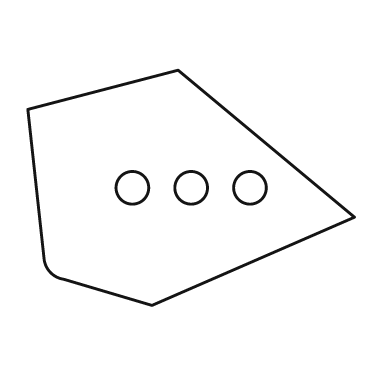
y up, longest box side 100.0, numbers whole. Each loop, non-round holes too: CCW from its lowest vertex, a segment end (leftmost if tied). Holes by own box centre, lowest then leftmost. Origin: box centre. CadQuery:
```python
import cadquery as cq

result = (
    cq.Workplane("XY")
    .moveTo(-12.0, -36.0)
    .lineTo(50.0, -9.0)
    .lineTo(-4.0, 36.0)
    .lineTo(-50.0, 24.0)
    .lineTo(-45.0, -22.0)
    .threePointArc((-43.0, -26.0), (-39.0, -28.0))
    .close()
    .moveTo(-18.0, 0.0)
    .circle(5.0)
    .moveTo(0.0, 0.0)
    .circle(5.0)
    .moveTo(18.0, 0.0)
    .circle(5.0)
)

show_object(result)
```